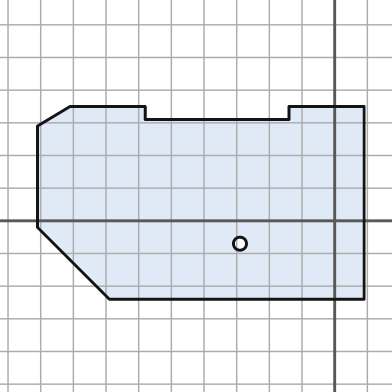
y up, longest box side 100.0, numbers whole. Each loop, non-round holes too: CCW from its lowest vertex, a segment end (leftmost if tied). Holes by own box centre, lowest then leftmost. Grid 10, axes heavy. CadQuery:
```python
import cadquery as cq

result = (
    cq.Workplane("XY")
    .moveTo(-69.0, -24.0)
    .lineTo(9.0, -24.0)
    .lineTo(9.0, 35.0)
    .lineTo(-14.0, 35.0)
    .lineTo(-14.0, 31.0)
    .lineTo(-58.0, 31.0)
    .lineTo(-58.0, 35.0)
    .lineTo(-81.0, 35.0)
    .lineTo(-91.0, 29.0)
    .lineTo(-91.0, -2.0)
    .close()
    .moveTo(-29.0, -7.0)
    .circle(2.0)
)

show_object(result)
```